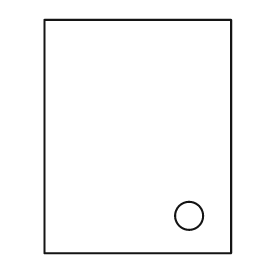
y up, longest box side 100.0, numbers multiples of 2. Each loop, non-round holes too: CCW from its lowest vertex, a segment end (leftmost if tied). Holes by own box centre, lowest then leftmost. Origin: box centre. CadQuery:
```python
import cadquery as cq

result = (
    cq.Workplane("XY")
    .moveTo(-40.0, -50.0)
    .lineTo(40.0, -50.0)
    .lineTo(40.0, 50.0)
    .lineTo(-40.0, 50.0)
    .close()
    .moveTo(22.0, -34.0)
    .circle(6.0)
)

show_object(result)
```